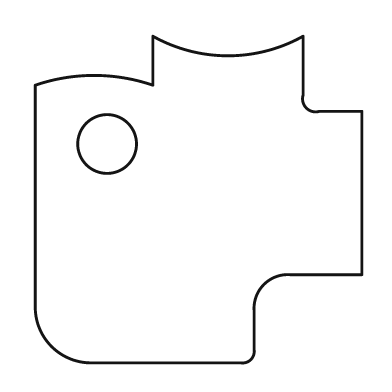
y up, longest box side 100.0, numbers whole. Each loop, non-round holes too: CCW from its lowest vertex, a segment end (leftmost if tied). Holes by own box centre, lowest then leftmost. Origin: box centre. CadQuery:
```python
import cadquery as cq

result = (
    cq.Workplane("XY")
    .moveTo(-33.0, -50.0)
    .lineTo(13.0, -50.0)
    .threePointArc((16.0, -49.0), (17.0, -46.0))
    .lineTo(17.0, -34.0)
    .threePointArc((20.0, -26.0), (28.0, -23.0))
    .lineTo(50.0, -23.0)
    .lineTo(50.0, 27.0)
    .lineTo(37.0, 27.0)
    .threePointArc((33.0, 28.0), (32.0, 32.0))
    .lineTo(32.0, 50.0)
    .threePointArc((9.0, 44.0), (-14.0, 50.0))
    .lineTo(-14.0, 35.0)
    .threePointArc((-32.0, 38.0), (-50.0, 35.0))
    .lineTo(-50.0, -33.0)
    .threePointArc((-45.0, -45.0), (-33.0, -50.0))
    .close()
    .moveTo(-28.0, 17.0)
    .circle(9.0)
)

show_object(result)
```